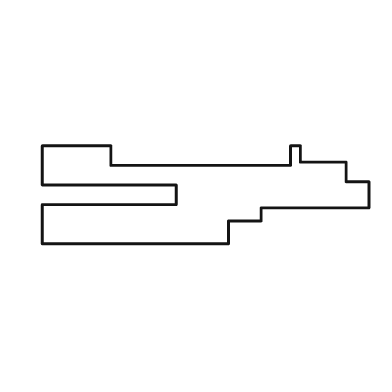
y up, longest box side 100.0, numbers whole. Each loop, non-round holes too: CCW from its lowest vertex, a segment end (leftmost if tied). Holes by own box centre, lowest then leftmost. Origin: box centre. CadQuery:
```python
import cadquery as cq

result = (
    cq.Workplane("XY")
    .moveTo(-50.0, -15.0)
    .lineTo(7.0, -15.0)
    .lineTo(7.0, -8.0)
    .lineTo(17.0, -8.0)
    .lineTo(17.0, -4.0)
    .lineTo(50.0, -4.0)
    .lineTo(50.0, 4.0)
    .lineTo(43.0, 4.0)
    .lineTo(43.0, 10.0)
    .lineTo(29.0, 10.0)
    .lineTo(29.0, 15.0)
    .lineTo(26.0, 15.0)
    .lineTo(26.0, 9.0)
    .lineTo(-29.0, 9.0)
    .lineTo(-29.0, 15.0)
    .lineTo(-50.0, 15.0)
    .lineTo(-50.0, 3.0)
    .lineTo(-9.0, 3.0)
    .lineTo(-9.0, -3.0)
    .lineTo(-50.0, -3.0)
    .close()
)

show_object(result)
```